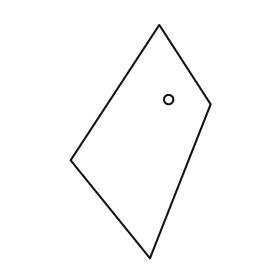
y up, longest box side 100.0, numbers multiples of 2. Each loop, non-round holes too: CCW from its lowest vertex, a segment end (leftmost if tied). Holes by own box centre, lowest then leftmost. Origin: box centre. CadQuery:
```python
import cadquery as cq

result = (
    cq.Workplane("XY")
    .moveTo(4.0, -50.0)
    .lineTo(30.0, 16.0)
    .lineTo(8.0, 50.0)
    .lineTo(-30.0, -8.0)
    .close()
    .moveTo(12.0, 18.0)
    .circle(2.0)
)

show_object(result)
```